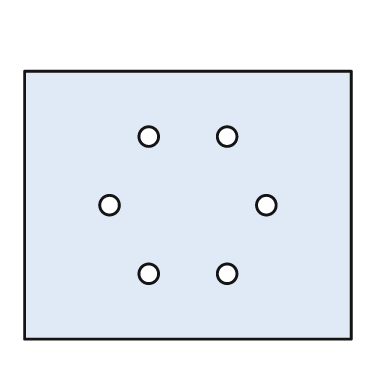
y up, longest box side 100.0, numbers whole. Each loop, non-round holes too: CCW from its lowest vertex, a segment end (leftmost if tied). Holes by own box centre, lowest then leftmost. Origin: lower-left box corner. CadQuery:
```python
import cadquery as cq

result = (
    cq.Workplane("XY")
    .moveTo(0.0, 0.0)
    .lineTo(100.0, 0.0)
    .lineTo(100.0, 82.0)
    .lineTo(0.0, 82.0)
    .close()
    .moveTo(38.0, 20.0)
    .circle(3.0)
    .moveTo(62.0, 20.0)
    .circle(3.0)
    .moveTo(26.0, 41.0)
    .circle(3.0)
    .moveTo(74.0, 41.0)
    .circle(3.0)
    .moveTo(38.0, 62.0)
    .circle(3.0)
    .moveTo(62.0, 62.0)
    .circle(3.0)
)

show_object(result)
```